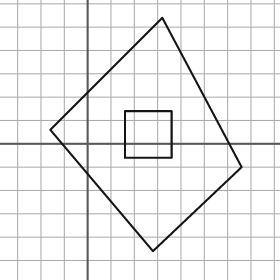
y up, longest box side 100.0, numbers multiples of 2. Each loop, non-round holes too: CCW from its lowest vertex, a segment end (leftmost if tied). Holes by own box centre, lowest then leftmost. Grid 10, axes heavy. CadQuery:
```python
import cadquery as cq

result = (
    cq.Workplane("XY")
    .moveTo(28.0, -46.0)
    .lineTo(66.0, -10.0)
    .lineTo(32.0, 54.0)
    .lineTo(-16.0, 6.0)
    .close()
    .moveTo(16.0, -6.0)
    .lineTo(36.0, -6.0)
    .lineTo(36.0, 14.0)
    .lineTo(16.0, 14.0)
    .close()
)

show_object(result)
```